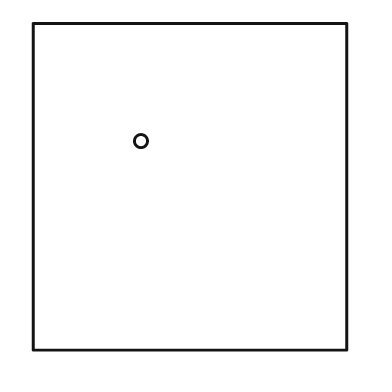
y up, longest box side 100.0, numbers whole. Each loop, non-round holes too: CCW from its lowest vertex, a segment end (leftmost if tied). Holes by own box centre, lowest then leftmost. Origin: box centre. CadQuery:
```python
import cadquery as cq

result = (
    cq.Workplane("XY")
    .moveTo(-48.0, -50.0)
    .lineTo(48.0, -50.0)
    .lineTo(48.0, 50.0)
    .lineTo(-48.0, 50.0)
    .close()
    .moveTo(-15.0, 14.0)
    .circle(2.0)
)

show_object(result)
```